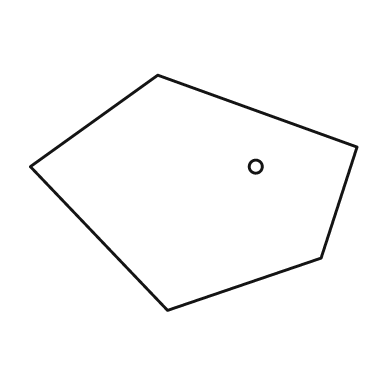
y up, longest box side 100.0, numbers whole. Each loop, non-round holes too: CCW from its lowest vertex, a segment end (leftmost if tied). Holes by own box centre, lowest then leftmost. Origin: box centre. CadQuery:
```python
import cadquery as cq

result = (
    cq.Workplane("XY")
    .moveTo(-8.0, -36.0)
    .lineTo(39.0, -20.0)
    .lineTo(50.0, 14.0)
    .lineTo(-11.0, 36.0)
    .lineTo(-50.0, 8.0)
    .close()
    .moveTo(19.0, 8.0)
    .circle(2.0)
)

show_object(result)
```